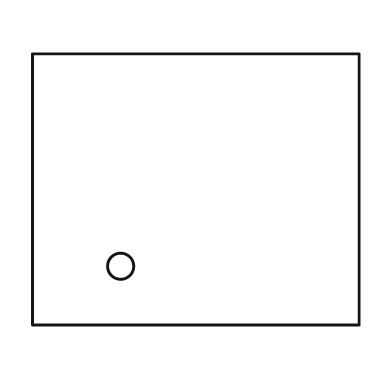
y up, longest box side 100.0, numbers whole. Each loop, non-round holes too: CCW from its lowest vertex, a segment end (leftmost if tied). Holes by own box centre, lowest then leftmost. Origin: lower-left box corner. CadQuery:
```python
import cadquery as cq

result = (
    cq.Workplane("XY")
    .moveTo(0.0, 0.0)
    .lineTo(100.0, 0.0)
    .lineTo(100.0, 83.0)
    .lineTo(0.0, 83.0)
    .close()
    .moveTo(27.0, 18.0)
    .circle(4.0)
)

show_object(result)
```